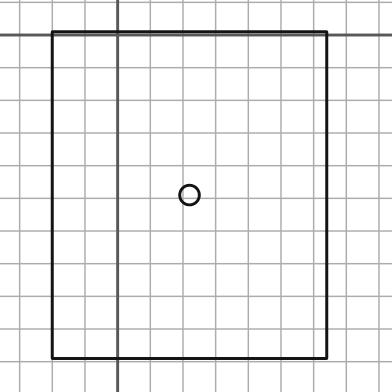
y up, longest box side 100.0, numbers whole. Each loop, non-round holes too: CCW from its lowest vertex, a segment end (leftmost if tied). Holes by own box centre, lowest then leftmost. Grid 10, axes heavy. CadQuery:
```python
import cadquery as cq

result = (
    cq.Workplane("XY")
    .moveTo(-20.0, -99.0)
    .lineTo(64.0, -99.0)
    .lineTo(64.0, 1.0)
    .lineTo(-20.0, 1.0)
    .close()
    .moveTo(22.0, -49.0)
    .circle(3.0)
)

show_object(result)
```